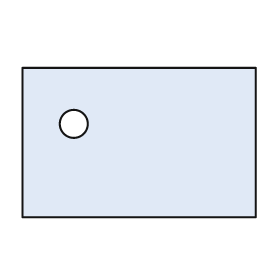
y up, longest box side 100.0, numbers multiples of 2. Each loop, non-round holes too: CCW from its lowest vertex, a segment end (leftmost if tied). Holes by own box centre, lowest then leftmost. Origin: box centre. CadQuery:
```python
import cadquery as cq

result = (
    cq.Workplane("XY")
    .moveTo(-50.0, -32.0)
    .lineTo(50.0, -32.0)
    .lineTo(50.0, 32.0)
    .lineTo(-50.0, 32.0)
    .close()
    .moveTo(-28.0, 8.0)
    .circle(6.0)
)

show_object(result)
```